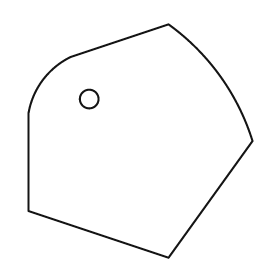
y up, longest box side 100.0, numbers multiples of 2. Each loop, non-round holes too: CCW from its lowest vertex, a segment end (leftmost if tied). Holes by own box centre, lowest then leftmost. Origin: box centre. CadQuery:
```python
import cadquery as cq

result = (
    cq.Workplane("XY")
    .moveTo(12.0, -50.0)
    .lineTo(48.0, 0.0)
    .threePointArc((34.0, 28.0), (12.0, 50.0))
    .lineTo(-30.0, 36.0)
    .threePointArc((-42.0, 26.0), (-48.0, 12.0))
    .lineTo(-48.0, -30.0)
    .close()
    .moveTo(-22.0, 18.0)
    .circle(4.0)
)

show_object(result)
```